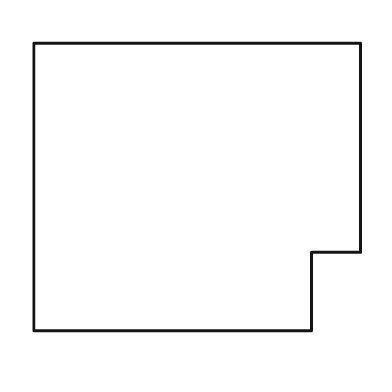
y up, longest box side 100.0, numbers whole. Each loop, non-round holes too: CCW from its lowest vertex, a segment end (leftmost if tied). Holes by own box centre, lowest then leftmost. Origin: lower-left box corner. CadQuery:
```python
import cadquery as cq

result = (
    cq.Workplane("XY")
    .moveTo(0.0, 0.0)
    .lineTo(85.0, 0.0)
    .lineTo(85.0, 24.0)
    .lineTo(100.0, 24.0)
    .lineTo(100.0, 88.0)
    .lineTo(0.0, 88.0)
    .close()
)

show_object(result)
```